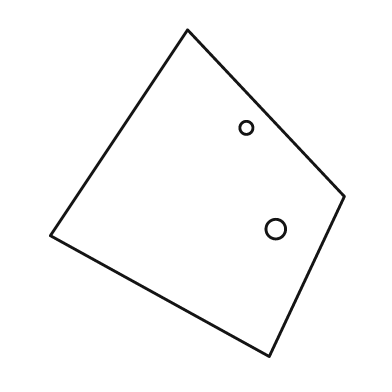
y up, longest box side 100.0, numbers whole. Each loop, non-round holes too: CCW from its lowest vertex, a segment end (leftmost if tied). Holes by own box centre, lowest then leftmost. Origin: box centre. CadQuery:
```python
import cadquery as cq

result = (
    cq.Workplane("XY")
    .moveTo(22.0, -50.0)
    .lineTo(45.0, -1.0)
    .lineTo(-3.0, 50.0)
    .lineTo(-45.0, -13.0)
    .close()
    .moveTo(24.0, -11.0)
    .circle(3.0)
    .moveTo(15.0, 20.0)
    .circle(2.0)
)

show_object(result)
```